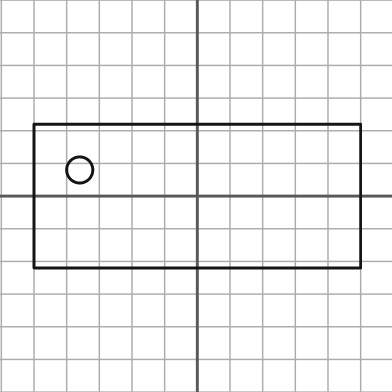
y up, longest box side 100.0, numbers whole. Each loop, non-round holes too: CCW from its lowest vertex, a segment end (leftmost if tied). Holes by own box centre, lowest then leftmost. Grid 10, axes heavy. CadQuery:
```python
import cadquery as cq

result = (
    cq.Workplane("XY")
    .moveTo(-50.0, -22.0)
    .lineTo(50.0, -22.0)
    .lineTo(50.0, 22.0)
    .lineTo(-50.0, 22.0)
    .close()
    .moveTo(-36.0, 8.0)
    .circle(4.0)
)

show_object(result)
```